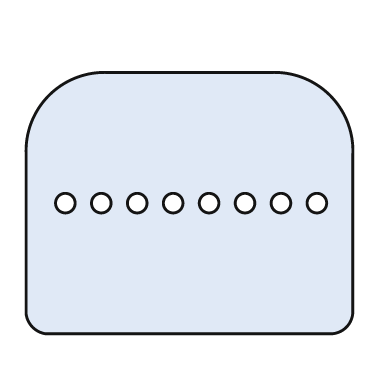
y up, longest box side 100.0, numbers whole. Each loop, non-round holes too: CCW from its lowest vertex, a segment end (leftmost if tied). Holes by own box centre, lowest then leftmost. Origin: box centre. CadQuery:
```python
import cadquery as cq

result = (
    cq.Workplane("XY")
    .moveTo(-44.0, -40.0)
    .lineTo(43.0, -40.0)
    .threePointArc((48.0, -38.0), (50.0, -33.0))
    .lineTo(50.0, 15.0)
    .threePointArc((43.0, 33.0), (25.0, 40.0))
    .lineTo(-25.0, 40.0)
    .threePointArc((-43.0, 33.0), (-50.0, 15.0))
    .lineTo(-50.0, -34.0)
    .threePointArc((-48.0, -38.0), (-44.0, -40.0))
    .close()
    .moveTo(-38.0, 0.0)
    .circle(3.0)
    .moveTo(-27.0, 0.0)
    .circle(3.0)
    .moveTo(-16.0, 0.0)
    .circle(3.0)
    .moveTo(-5.0, 0.0)
    .circle(3.0)
    .moveTo(6.0, 0.0)
    .circle(3.0)
    .moveTo(17.0, 0.0)
    .circle(3.0)
    .moveTo(28.0, 0.0)
    .circle(3.0)
    .moveTo(39.0, 0.0)
    .circle(3.0)
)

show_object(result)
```